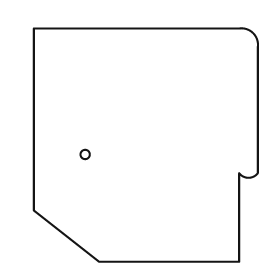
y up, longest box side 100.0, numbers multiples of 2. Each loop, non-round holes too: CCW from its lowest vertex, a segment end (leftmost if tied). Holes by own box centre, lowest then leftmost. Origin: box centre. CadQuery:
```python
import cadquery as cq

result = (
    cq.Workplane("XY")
    .moveTo(-20.0, -50.0)
    .lineTo(40.0, -50.0)
    .lineTo(40.0, -12.0)
    .threePointArc((44.0, -14.0), (48.0, -12.0))
    .lineTo(48.0, 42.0)
    .threePointArc((46.0, 48.0), (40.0, 50.0))
    .lineTo(-48.0, 50.0)
    .lineTo(-48.0, -28.0)
    .close()
    .moveTo(-26.0, -4.0)
    .circle(2.0)
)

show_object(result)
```